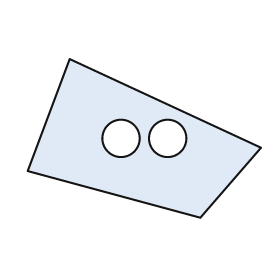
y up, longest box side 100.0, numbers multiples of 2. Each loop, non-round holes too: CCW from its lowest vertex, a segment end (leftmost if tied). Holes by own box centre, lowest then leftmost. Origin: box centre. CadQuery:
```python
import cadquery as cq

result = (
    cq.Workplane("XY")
    .moveTo(24.0, -34.0)
    .lineTo(50.0, -4.0)
    .lineTo(-32.0, 34.0)
    .lineTo(-50.0, -14.0)
    .close()
    .moveTo(-10.0, 0.0)
    .circle(8.0)
    .moveTo(10.0, 0.0)
    .circle(8.0)
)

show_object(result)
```